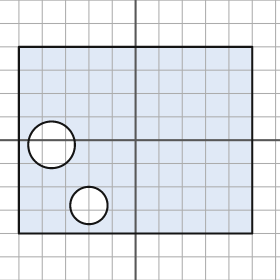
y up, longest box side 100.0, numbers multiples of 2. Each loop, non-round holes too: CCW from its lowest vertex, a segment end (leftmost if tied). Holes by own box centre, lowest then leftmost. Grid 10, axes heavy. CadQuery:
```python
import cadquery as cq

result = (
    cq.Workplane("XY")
    .moveTo(-50.0, -40.0)
    .lineTo(50.0, -40.0)
    .lineTo(50.0, 40.0)
    .lineTo(-50.0, 40.0)
    .close()
    .moveTo(-20.0, -28.0)
    .circle(8.0)
    .moveTo(-36.0, -2.0)
    .circle(10.0)
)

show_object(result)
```